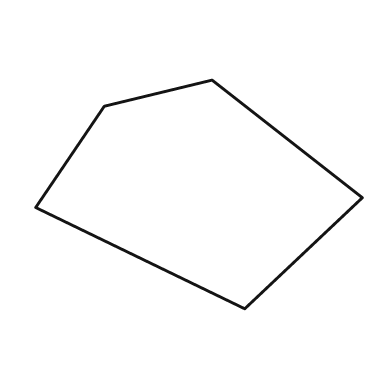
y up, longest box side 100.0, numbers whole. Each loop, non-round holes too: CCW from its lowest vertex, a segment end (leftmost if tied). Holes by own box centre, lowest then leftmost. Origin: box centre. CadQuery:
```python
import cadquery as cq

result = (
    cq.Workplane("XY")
    .moveTo(14.0, -35.0)
    .lineTo(50.0, -1.0)
    .lineTo(4.0, 35.0)
    .lineTo(-29.0, 27.0)
    .lineTo(-50.0, -4.0)
    .close()
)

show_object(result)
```